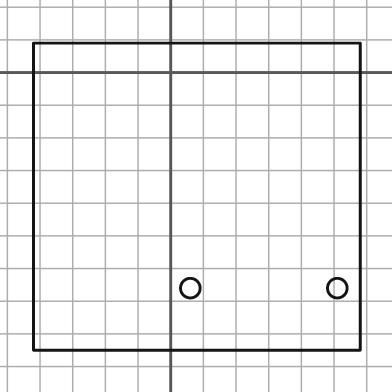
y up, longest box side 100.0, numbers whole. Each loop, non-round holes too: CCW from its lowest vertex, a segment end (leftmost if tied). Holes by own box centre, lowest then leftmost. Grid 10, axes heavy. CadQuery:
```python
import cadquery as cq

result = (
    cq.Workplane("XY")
    .moveTo(-42.0, -85.0)
    .lineTo(58.0, -85.0)
    .lineTo(58.0, 9.0)
    .lineTo(-42.0, 9.0)
    .close()
    .moveTo(6.0, -66.0)
    .circle(3.0)
    .moveTo(51.0, -66.0)
    .circle(3.0)
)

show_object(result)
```